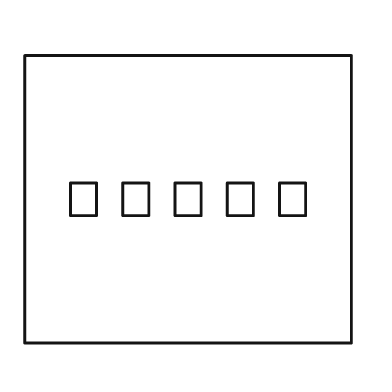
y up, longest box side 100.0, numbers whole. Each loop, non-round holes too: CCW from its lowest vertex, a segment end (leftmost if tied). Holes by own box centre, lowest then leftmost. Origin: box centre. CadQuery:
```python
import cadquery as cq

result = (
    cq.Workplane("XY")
    .moveTo(-50.0, -44.0)
    .lineTo(50.0, -44.0)
    .lineTo(50.0, 44.0)
    .lineTo(-50.0, 44.0)
    .close()
    .moveTo(-36.0, -5.0)
    .lineTo(-28.0, -5.0)
    .lineTo(-28.0, 5.0)
    .lineTo(-36.0, 5.0)
    .close()
    .moveTo(-20.0, -5.0)
    .lineTo(-12.0, -5.0)
    .lineTo(-12.0, 5.0)
    .lineTo(-20.0, 5.0)
    .close()
    .moveTo(-4.0, -5.0)
    .lineTo(4.0, -5.0)
    .lineTo(4.0, 5.0)
    .lineTo(-4.0, 5.0)
    .close()
    .moveTo(12.0, -5.0)
    .lineTo(20.0, -5.0)
    .lineTo(20.0, 5.0)
    .lineTo(12.0, 5.0)
    .close()
    .moveTo(28.0, -5.0)
    .lineTo(36.0, -5.0)
    .lineTo(36.0, 5.0)
    .lineTo(28.0, 5.0)
    .close()
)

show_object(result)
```